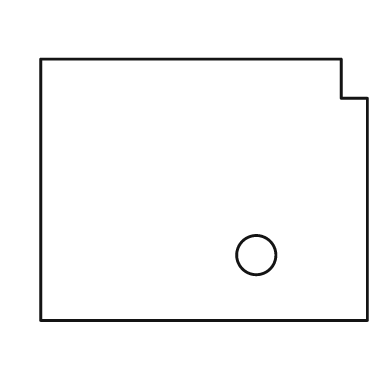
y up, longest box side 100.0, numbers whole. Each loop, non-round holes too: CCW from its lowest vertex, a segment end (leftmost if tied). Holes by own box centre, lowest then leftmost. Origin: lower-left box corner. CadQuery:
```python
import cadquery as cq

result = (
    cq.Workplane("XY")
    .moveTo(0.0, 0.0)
    .lineTo(100.0, 0.0)
    .lineTo(100.0, 68.0)
    .lineTo(92.0, 68.0)
    .lineTo(92.0, 80.0)
    .lineTo(0.0, 80.0)
    .close()
    .moveTo(66.0, 20.0)
    .circle(6.0)
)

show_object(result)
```